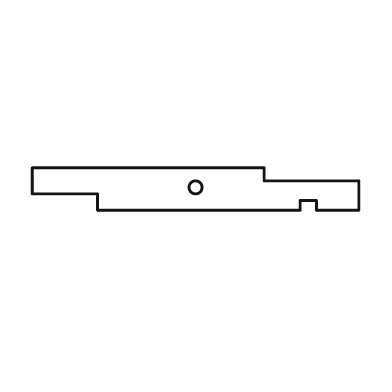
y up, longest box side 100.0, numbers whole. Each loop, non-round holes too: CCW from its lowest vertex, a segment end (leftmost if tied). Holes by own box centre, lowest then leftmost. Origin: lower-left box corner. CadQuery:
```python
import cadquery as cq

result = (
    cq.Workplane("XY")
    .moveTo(20.0, 0.0)
    .lineTo(82.0, 0.0)
    .lineTo(82.0, 3.0)
    .lineTo(87.0, 3.0)
    .lineTo(87.0, 0.0)
    .lineTo(100.0, 0.0)
    .lineTo(100.0, 9.0)
    .lineTo(71.0, 9.0)
    .lineTo(71.0, 13.0)
    .lineTo(0.0, 13.0)
    .lineTo(0.0, 5.0)
    .lineTo(20.0, 5.0)
    .close()
    .moveTo(50.0, 7.0)
    .circle(2.0)
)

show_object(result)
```